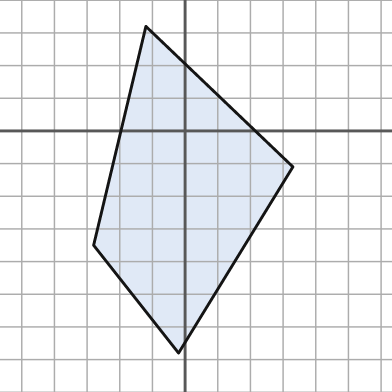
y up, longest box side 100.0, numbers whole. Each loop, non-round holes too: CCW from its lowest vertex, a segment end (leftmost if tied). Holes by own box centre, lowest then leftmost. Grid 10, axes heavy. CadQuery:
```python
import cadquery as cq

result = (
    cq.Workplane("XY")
    .moveTo(-2.0, -68.0)
    .lineTo(33.0, -11.0)
    .lineTo(-12.0, 32.0)
    .lineTo(-28.0, -35.0)
    .close()
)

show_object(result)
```